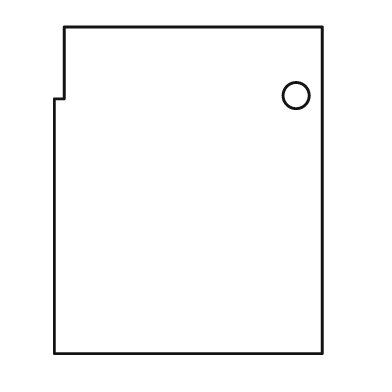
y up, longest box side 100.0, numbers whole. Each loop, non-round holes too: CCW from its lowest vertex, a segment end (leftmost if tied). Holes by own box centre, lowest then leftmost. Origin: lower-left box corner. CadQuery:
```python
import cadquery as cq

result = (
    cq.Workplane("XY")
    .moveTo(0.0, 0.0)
    .lineTo(82.0, 0.0)
    .lineTo(82.0, 100.0)
    .lineTo(3.0, 100.0)
    .lineTo(3.0, 78.0)
    .lineTo(0.0, 78.0)
    .close()
    .moveTo(74.0, 79.0)
    .circle(4.0)
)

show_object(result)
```